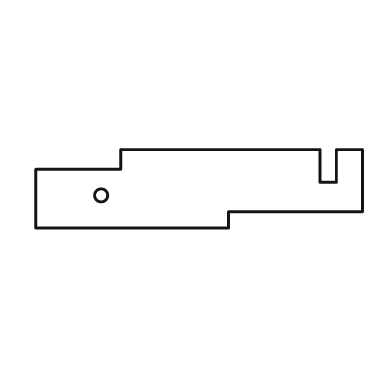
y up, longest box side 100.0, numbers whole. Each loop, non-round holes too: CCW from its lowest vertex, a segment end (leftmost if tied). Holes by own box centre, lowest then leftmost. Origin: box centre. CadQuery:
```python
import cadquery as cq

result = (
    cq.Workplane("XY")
    .moveTo(-50.0, -12.0)
    .lineTo(9.0, -12.0)
    .lineTo(9.0, -7.0)
    .lineTo(50.0, -7.0)
    .lineTo(50.0, 12.0)
    .lineTo(42.0, 12.0)
    .lineTo(42.0, 2.0)
    .lineTo(37.0, 2.0)
    .lineTo(37.0, 12.0)
    .lineTo(-24.0, 12.0)
    .lineTo(-24.0, 6.0)
    .lineTo(-50.0, 6.0)
    .close()
    .moveTo(-30.0, -2.0)
    .circle(2.0)
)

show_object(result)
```